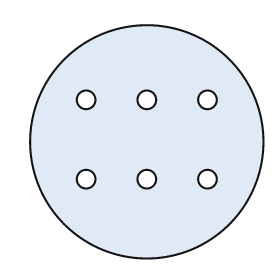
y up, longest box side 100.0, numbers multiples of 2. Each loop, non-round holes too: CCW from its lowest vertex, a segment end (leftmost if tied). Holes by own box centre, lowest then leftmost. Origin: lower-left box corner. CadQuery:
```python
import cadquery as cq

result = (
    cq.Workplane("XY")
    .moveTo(50.0, 50.0)
    .circle(50.0)
    .moveTo(24.0, 34.0)
    .circle(4.0)
    .moveTo(50.0, 34.0)
    .circle(4.0)
    .moveTo(76.0, 34.0)
    .circle(4.0)
    .moveTo(24.0, 68.0)
    .circle(4.0)
    .moveTo(50.0, 68.0)
    .circle(4.0)
    .moveTo(76.0, 68.0)
    .circle(4.0)
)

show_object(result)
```